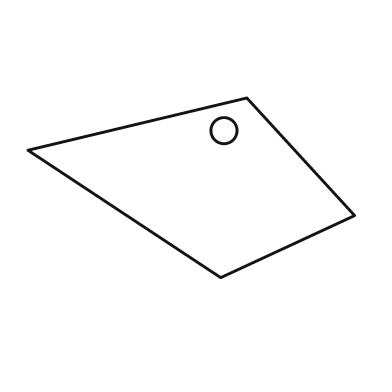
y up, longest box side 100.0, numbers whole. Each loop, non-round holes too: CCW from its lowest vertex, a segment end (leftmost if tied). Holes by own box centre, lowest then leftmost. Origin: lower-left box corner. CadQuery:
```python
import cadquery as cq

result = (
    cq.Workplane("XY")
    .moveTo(59.0, 0.0)
    .lineTo(100.0, 19.0)
    .lineTo(67.0, 55.0)
    .lineTo(0.0, 39.0)
    .close()
    .moveTo(60.0, 45.0)
    .circle(4.0)
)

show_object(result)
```